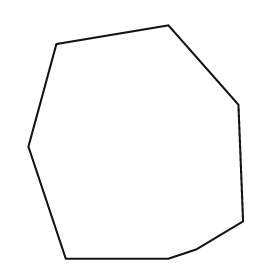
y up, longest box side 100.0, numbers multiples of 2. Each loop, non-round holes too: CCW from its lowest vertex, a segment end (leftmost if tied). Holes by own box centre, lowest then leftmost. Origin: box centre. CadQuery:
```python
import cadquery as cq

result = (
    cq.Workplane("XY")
    .moveTo(-30.0, -50.0)
    .lineTo(14.0, -50.0)
    .lineTo(26.0, -46.0)
    .lineTo(46.0, -34.0)
    .lineTo(44.0, 16.0)
    .lineTo(14.0, 50.0)
    .lineTo(-34.0, 42.0)
    .lineTo(-46.0, -2.0)
    .close()
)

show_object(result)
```